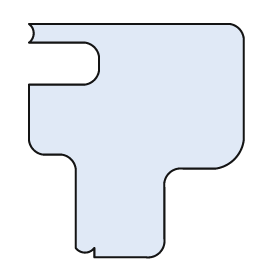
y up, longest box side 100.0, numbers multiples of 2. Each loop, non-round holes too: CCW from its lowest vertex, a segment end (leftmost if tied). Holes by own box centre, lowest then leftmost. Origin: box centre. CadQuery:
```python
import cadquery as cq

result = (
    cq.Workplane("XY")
    .moveTo(-18.0, -50.0)
    .lineTo(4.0, -50.0)
    .threePointArc((10.0, -48.0), (12.0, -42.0))
    .lineTo(12.0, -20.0)
    .threePointArc((14.0, -14.0), (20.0, -12.0))
    .lineTo(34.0, -12.0)
    .threePointArc((42.0, -8.0), (46.0, 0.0))
    .lineTo(46.0, 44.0)
    .threePointArc((44.0, 48.0), (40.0, 50.0))
    .lineTo(-46.0, 50.0)
    .threePointArc((-44.0, 46.0), (-46.0, 42.0))
    .lineTo(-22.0, 42.0)
    .threePointArc((-18.0, 40.0), (-16.0, 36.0))
    .lineTo(-16.0, 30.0)
    .threePointArc((-18.0, 26.0), (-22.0, 24.0))
    .lineTo(-46.0, 24.0)
    .lineTo(-46.0, 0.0)
    .threePointArc((-44.0, -4.0), (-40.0, -6.0))
    .lineTo(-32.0, -6.0)
    .threePointArc((-28.0, -8.0), (-26.0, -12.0))
    .lineTo(-26.0, -46.0)
    .threePointArc((-22.0, -48.0), (-18.0, -46.0))
    .close()
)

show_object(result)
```